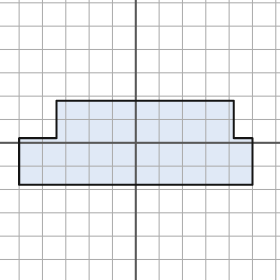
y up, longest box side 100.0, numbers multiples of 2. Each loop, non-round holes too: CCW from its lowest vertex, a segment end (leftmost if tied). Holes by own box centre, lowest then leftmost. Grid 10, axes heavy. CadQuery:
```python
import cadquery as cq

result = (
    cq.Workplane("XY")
    .moveTo(-50.0, -18.0)
    .lineTo(50.0, -18.0)
    .lineTo(50.0, 2.0)
    .lineTo(42.0, 2.0)
    .lineTo(42.0, 18.0)
    .lineTo(-34.0, 18.0)
    .lineTo(-34.0, 2.0)
    .lineTo(-50.0, 2.0)
    .close()
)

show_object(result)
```